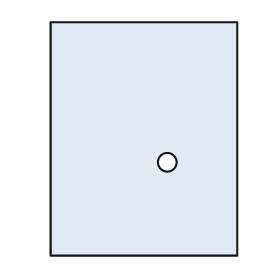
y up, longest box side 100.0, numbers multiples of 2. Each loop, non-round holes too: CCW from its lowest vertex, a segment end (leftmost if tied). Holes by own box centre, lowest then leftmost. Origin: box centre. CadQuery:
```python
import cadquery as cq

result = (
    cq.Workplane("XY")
    .moveTo(-40.0, -50.0)
    .lineTo(40.0, -50.0)
    .lineTo(40.0, 50.0)
    .lineTo(-40.0, 50.0)
    .close()
    .moveTo(10.0, -10.0)
    .circle(4.0)
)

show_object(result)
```